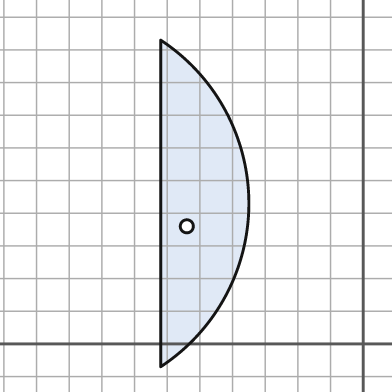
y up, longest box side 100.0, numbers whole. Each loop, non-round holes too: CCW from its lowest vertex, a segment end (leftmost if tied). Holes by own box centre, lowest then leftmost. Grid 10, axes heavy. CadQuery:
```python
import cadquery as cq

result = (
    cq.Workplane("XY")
    .moveTo(-62.0, -7.0)
    .threePointArc((-35.0, 43.0), (-62.0, 93.0))
    .close()
    .moveTo(-54.0, 36.0)
    .circle(2.0)
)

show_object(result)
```